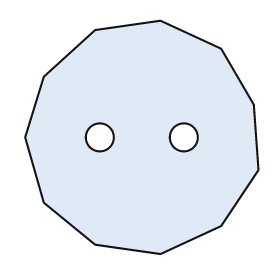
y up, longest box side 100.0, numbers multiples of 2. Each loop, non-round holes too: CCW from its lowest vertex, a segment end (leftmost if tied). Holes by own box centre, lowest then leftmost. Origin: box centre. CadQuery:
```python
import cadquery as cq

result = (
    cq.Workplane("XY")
    .moveTo(8.0, -50.0)
    .lineTo(34.0, -38.0)
    .lineTo(50.0, -14.0)
    .lineTo(48.0, 14.0)
    .lineTo(34.0, 38.0)
    .lineTo(8.0, 50.0)
    .lineTo(-20.0, 46.0)
    .lineTo(-42.0, 26.0)
    .lineTo(-50.0, 0.0)
    .lineTo(-42.0, -28.0)
    .lineTo(-20.0, -46.0)
    .close()
    .moveTo(-18.0, 0.0)
    .circle(6.0)
    .moveTo(18.0, 0.0)
    .circle(6.0)
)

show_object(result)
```